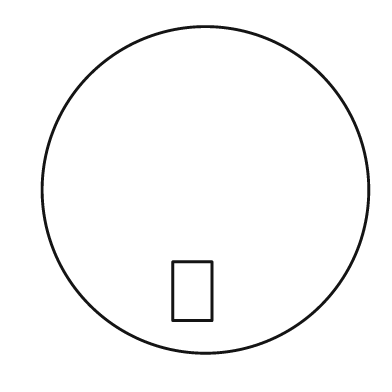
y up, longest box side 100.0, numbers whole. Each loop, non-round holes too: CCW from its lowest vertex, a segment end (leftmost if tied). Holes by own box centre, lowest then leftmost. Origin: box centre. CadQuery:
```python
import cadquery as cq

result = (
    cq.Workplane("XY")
    .moveTo(0.0, 0.0)
    .circle(50.0)
    .moveTo(-10.0, -40.0)
    .lineTo(2.0, -40.0)
    .lineTo(2.0, -22.0)
    .lineTo(-10.0, -22.0)
    .close()
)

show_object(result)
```